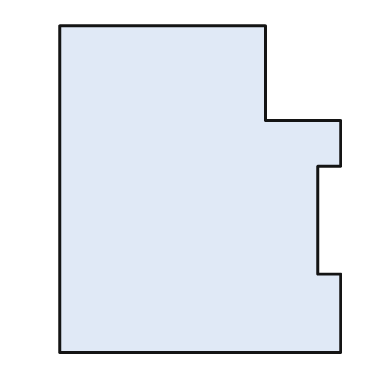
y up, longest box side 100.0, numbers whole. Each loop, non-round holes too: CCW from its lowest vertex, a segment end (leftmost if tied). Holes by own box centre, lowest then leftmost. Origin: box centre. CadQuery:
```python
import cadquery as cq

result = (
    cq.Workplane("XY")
    .moveTo(-43.0, -50.0)
    .lineTo(43.0, -50.0)
    .lineTo(43.0, -26.0)
    .lineTo(36.0, -26.0)
    .lineTo(36.0, 7.0)
    .lineTo(43.0, 7.0)
    .lineTo(43.0, 21.0)
    .lineTo(20.0, 21.0)
    .lineTo(20.0, 50.0)
    .lineTo(-43.0, 50.0)
    .close()
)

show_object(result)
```